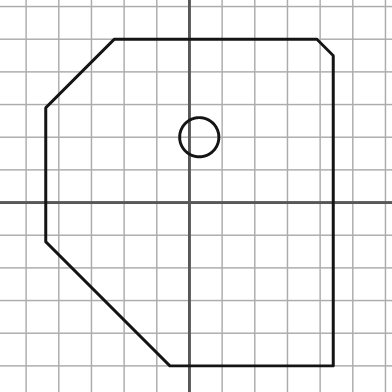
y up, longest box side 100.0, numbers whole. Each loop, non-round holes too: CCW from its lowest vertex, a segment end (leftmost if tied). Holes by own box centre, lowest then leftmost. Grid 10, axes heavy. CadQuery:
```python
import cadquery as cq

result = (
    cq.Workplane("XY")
    .moveTo(-6.0, -50.0)
    .lineTo(44.0, -50.0)
    .lineTo(44.0, 45.0)
    .lineTo(39.0, 50.0)
    .lineTo(-23.0, 50.0)
    .lineTo(-44.0, 29.0)
    .lineTo(-44.0, -12.0)
    .close()
    .moveTo(3.0, 20.0)
    .circle(6.0)
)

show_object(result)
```